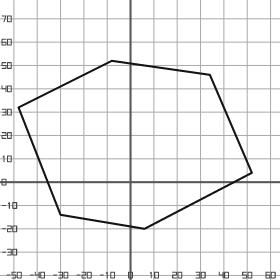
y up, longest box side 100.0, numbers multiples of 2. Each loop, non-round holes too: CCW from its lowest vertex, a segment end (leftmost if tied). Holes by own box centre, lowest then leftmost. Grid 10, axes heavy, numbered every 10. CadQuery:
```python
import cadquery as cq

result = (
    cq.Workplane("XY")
    .moveTo(6.0, -20.0)
    .lineTo(52.0, 4.0)
    .lineTo(34.0, 46.0)
    .lineTo(-8.0, 52.0)
    .lineTo(-48.0, 32.0)
    .lineTo(-30.0, -14.0)
    .close()
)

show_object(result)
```